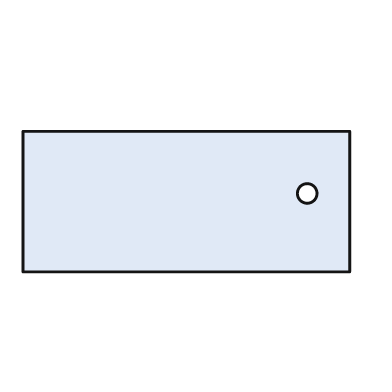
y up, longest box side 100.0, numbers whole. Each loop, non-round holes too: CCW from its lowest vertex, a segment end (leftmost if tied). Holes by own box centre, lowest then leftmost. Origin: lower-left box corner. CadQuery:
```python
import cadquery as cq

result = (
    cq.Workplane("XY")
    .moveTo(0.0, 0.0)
    .lineTo(100.0, 0.0)
    .lineTo(100.0, 43.0)
    .lineTo(0.0, 43.0)
    .close()
    .moveTo(87.0, 24.0)
    .circle(3.0)
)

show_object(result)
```